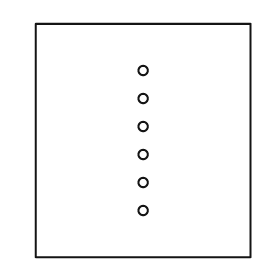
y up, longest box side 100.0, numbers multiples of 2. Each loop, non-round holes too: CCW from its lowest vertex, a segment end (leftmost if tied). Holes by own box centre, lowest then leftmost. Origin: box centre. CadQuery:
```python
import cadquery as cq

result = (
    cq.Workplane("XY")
    .moveTo(-46.0, -50.0)
    .lineTo(46.0, -50.0)
    .lineTo(46.0, 50.0)
    .lineTo(-46.0, 50.0)
    .close()
    .moveTo(0.0, -30.0)
    .circle(2.0)
    .moveTo(0.0, -18.0)
    .circle(2.0)
    .moveTo(0.0, -6.0)
    .circle(2.0)
    .moveTo(0.0, 6.0)
    .circle(2.0)
    .moveTo(0.0, 18.0)
    .circle(2.0)
    .moveTo(0.0, 30.0)
    .circle(2.0)
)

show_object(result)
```